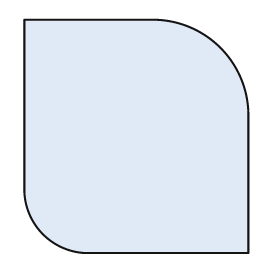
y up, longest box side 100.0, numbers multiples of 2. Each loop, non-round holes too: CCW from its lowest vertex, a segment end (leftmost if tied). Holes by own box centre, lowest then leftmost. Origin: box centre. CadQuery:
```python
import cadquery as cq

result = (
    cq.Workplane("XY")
    .moveTo(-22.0, -50.0)
    .lineTo(48.0, -50.0)
    .lineTo(48.0, 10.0)
    .threePointArc((36.0, 38.0), (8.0, 50.0))
    .lineTo(-48.0, 50.0)
    .lineTo(-48.0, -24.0)
    .threePointArc((-40.0, -42.0), (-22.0, -50.0))
    .close()
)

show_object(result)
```